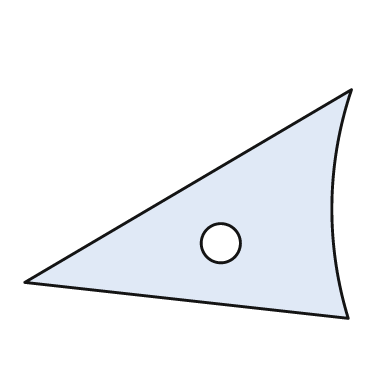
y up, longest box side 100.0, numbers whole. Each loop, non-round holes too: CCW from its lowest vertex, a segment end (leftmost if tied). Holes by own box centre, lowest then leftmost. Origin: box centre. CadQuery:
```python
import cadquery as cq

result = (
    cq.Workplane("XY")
    .moveTo(49.0, -35.0)
    .threePointArc((44.0, 0.0), (50.0, 35.0))
    .lineTo(-50.0, -24.0)
    .close()
    .moveTo(10.0, -12.0)
    .circle(6.0)
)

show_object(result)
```